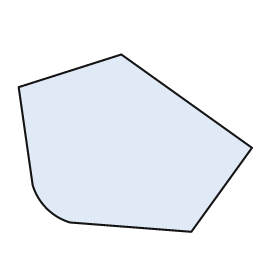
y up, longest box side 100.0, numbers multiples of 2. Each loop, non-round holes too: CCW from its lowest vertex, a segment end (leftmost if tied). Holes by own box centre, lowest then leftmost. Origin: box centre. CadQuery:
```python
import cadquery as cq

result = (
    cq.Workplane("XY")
    .moveTo(24.0, -38.0)
    .lineTo(50.0, -2.0)
    .lineTo(-6.0, 38.0)
    .lineTo(-50.0, 24.0)
    .lineTo(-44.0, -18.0)
    .threePointArc((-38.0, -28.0), (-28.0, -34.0))
    .close()
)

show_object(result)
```